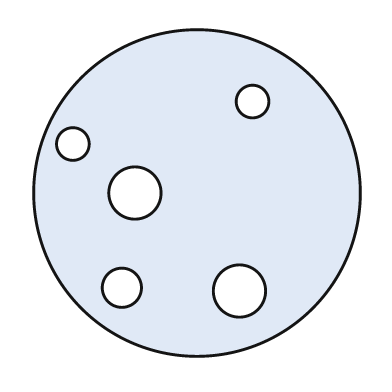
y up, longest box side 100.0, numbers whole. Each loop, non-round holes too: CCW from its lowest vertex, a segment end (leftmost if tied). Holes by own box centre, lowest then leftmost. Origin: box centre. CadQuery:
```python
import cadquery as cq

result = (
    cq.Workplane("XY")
    .moveTo(0.0, 0.0)
    .circle(50.0)
    .moveTo(13.0, -30.0)
    .circle(8.0)
    .moveTo(-23.0, -29.0)
    .circle(6.0)
    .moveTo(-19.0, 0.0)
    .circle(8.0)
    .moveTo(-38.0, 15.0)
    .circle(5.0)
    .moveTo(17.0, 28.0)
    .circle(5.0)
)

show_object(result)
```